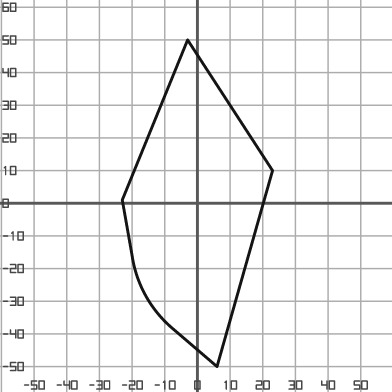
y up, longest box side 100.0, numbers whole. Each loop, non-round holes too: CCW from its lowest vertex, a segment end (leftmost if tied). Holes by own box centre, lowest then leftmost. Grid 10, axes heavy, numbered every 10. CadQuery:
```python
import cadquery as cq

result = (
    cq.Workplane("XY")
    .moveTo(6.0, -50.0)
    .lineTo(23.0, 10.0)
    .lineTo(-3.0, 50.0)
    .lineTo(-23.0, 1.0)
    .lineTo(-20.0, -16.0)
    .threePointArc((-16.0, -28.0), (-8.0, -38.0))
    .close()
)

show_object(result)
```